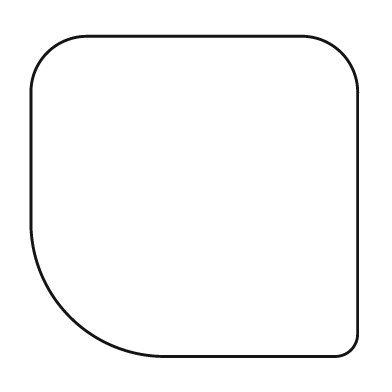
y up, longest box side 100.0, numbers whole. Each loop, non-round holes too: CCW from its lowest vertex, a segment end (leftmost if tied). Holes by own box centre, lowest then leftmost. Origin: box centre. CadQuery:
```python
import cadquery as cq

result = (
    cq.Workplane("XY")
    .moveTo(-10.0, -49.0)
    .lineTo(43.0, -49.0)
    .threePointArc((48.0, -47.0), (50.0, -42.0))
    .lineTo(50.0, 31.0)
    .threePointArc((45.0, 44.0), (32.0, 49.0))
    .lineTo(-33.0, 49.0)
    .threePointArc((-45.0, 44.0), (-50.0, 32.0))
    .lineTo(-50.0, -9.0)
    .threePointArc((-38.0, -37.0), (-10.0, -49.0))
    .close()
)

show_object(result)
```